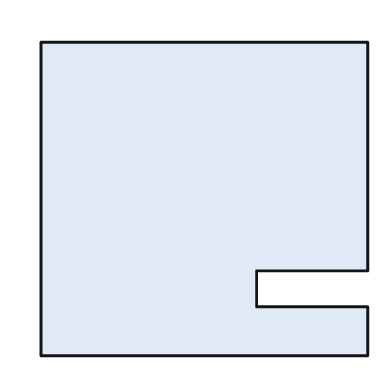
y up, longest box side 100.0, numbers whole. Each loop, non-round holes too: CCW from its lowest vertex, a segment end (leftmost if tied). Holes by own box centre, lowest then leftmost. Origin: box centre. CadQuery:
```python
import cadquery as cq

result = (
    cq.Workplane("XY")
    .moveTo(-50.0, -48.0)
    .lineTo(50.0, -48.0)
    .lineTo(50.0, -33.0)
    .lineTo(16.0, -33.0)
    .lineTo(16.0, -22.0)
    .lineTo(50.0, -22.0)
    .lineTo(50.0, 48.0)
    .lineTo(-50.0, 48.0)
    .close()
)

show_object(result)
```